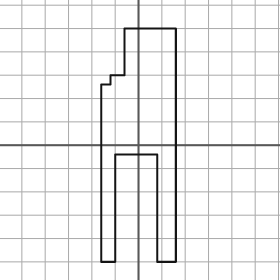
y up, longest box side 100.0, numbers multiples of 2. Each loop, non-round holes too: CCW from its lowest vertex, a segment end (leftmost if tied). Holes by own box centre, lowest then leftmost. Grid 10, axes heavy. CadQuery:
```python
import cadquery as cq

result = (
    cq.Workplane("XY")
    .moveTo(-16.0, -50.0)
    .lineTo(-10.0, -50.0)
    .lineTo(-10.0, -4.0)
    .lineTo(8.0, -4.0)
    .lineTo(8.0, -50.0)
    .lineTo(16.0, -50.0)
    .lineTo(16.0, 50.0)
    .lineTo(-6.0, 50.0)
    .lineTo(-6.0, 30.0)
    .lineTo(-12.0, 30.0)
    .lineTo(-12.0, 26.0)
    .lineTo(-16.0, 26.0)
    .close()
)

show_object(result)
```